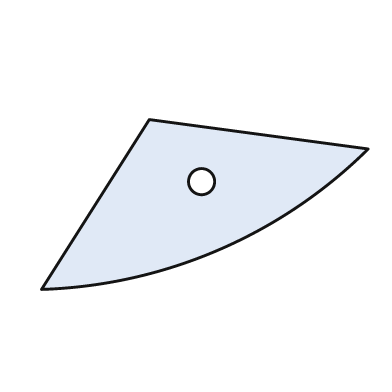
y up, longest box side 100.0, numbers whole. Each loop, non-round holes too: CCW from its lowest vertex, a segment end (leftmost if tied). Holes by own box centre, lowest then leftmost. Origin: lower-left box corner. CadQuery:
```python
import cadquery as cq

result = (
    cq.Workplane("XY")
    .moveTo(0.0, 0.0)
    .threePointArc((54.0, 12.0), (100.0, 43.0))
    .lineTo(33.0, 52.0)
    .close()
    .moveTo(49.0, 33.0)
    .circle(4.0)
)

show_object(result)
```